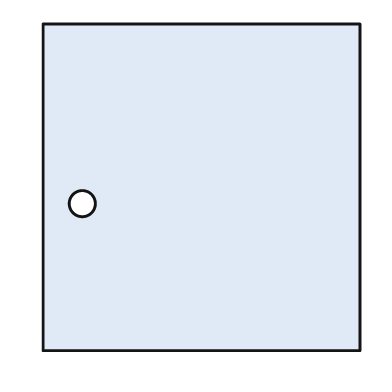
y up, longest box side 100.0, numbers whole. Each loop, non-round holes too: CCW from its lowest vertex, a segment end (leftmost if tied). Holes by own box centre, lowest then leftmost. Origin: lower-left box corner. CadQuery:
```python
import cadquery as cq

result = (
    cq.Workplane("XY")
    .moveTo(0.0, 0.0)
    .lineTo(97.0, 0.0)
    .lineTo(97.0, 100.0)
    .lineTo(0.0, 100.0)
    .close()
    .moveTo(12.0, 45.0)
    .circle(4.0)
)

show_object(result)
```